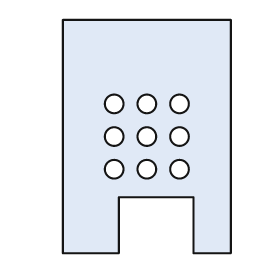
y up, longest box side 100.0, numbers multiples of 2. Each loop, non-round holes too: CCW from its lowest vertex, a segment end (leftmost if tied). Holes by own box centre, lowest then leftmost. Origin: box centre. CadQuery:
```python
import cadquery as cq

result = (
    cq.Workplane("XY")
    .moveTo(-36.0, -50.0)
    .lineTo(-12.0, -50.0)
    .lineTo(-12.0, -26.0)
    .lineTo(20.0, -26.0)
    .lineTo(20.0, -50.0)
    .lineTo(36.0, -50.0)
    .lineTo(36.0, 50.0)
    .lineTo(-36.0, 50.0)
    .close()
    .moveTo(-14.0, -14.0)
    .circle(4.0)
    .moveTo(0.0, -14.0)
    .circle(4.0)
    .moveTo(14.0, -14.0)
    .circle(4.0)
    .moveTo(-14.0, 0.0)
    .circle(4.0)
    .moveTo(0.0, 0.0)
    .circle(4.0)
    .moveTo(14.0, 0.0)
    .circle(4.0)
    .moveTo(-14.0, 14.0)
    .circle(4.0)
    .moveTo(0.0, 14.0)
    .circle(4.0)
    .moveTo(14.0, 14.0)
    .circle(4.0)
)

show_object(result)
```